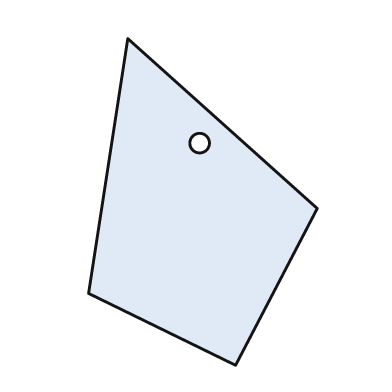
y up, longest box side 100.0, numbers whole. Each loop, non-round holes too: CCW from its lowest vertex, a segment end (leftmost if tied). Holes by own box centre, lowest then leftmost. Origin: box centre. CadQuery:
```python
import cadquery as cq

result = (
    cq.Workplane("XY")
    .moveTo(10.0, -50.0)
    .lineTo(35.0, -2.0)
    .lineTo(-23.0, 50.0)
    .lineTo(-35.0, -28.0)
    .close()
    .moveTo(-1.0, 18.0)
    .circle(3.0)
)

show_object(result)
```